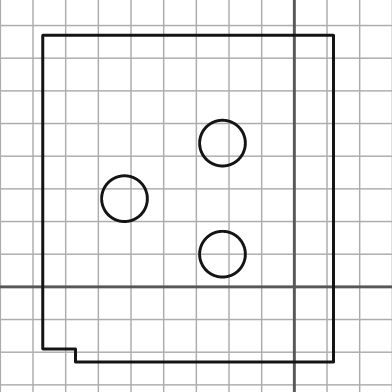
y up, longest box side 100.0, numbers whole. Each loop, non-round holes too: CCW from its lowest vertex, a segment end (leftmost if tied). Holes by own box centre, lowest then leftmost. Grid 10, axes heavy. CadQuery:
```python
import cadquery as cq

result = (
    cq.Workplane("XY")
    .moveTo(-67.0, -23.0)
    .lineTo(12.0, -23.0)
    .lineTo(12.0, 77.0)
    .lineTo(-77.0, 77.0)
    .lineTo(-77.0, -19.0)
    .lineTo(-67.0, -19.0)
    .close()
    .moveTo(-22.0, 10.0)
    .circle(7.0)
    .moveTo(-52.0, 27.0)
    .circle(7.0)
    .moveTo(-22.0, 44.0)
    .circle(7.0)
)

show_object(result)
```